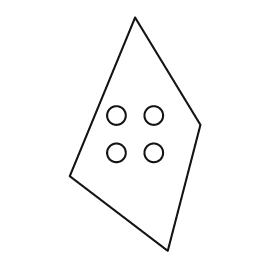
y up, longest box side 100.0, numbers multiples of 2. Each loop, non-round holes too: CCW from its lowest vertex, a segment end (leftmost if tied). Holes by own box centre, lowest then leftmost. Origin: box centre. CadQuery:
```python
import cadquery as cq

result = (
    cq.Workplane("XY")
    .moveTo(14.0, -50.0)
    .lineTo(28.0, 4.0)
    .lineTo(0.0, 50.0)
    .lineTo(-28.0, -18.0)
    .close()
    .moveTo(-8.0, -8.0)
    .circle(4.0)
    .moveTo(8.0, -8.0)
    .circle(4.0)
    .moveTo(-8.0, 8.0)
    .circle(4.0)
    .moveTo(8.0, 8.0)
    .circle(4.0)
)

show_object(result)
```